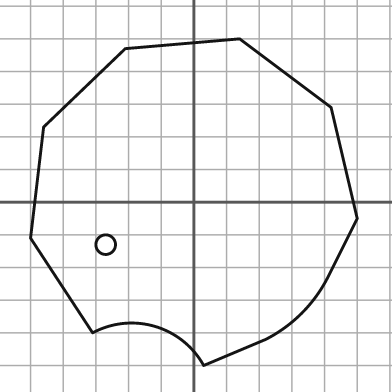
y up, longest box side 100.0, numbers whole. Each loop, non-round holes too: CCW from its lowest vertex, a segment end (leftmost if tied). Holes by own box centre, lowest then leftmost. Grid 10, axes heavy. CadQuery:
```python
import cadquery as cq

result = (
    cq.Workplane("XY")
    .moveTo(3.0, -50.0)
    .lineTo(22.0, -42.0)
    .threePointArc((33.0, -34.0), (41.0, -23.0))
    .lineTo(50.0, -5.0)
    .lineTo(42.0, 29.0)
    .lineTo(14.0, 50.0)
    .lineTo(-21.0, 47.0)
    .lineTo(-46.0, 23.0)
    .lineTo(-50.0, -11.0)
    .lineTo(-31.0, -40.0)
    .threePointArc((-12.0, -38.0), (3.0, -50.0))
    .close()
    .moveTo(-27.0, -13.0)
    .circle(3.0)
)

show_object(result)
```